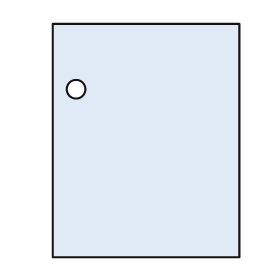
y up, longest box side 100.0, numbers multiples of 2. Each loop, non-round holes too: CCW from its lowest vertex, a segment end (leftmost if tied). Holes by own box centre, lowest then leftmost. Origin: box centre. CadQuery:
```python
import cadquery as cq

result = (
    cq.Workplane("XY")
    .moveTo(-40.0, -50.0)
    .lineTo(40.0, -50.0)
    .lineTo(40.0, 50.0)
    .lineTo(-40.0, 50.0)
    .close()
    .moveTo(-30.0, 22.0)
    .circle(4.0)
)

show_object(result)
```